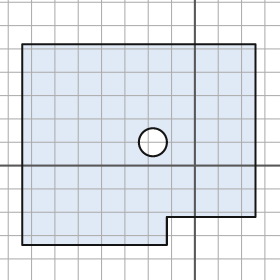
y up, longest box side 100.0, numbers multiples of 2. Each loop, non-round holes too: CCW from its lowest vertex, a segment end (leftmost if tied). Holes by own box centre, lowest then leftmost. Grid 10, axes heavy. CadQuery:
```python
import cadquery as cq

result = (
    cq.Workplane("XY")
    .moveTo(-74.0, -34.0)
    .lineTo(-12.0, -34.0)
    .lineTo(-12.0, -22.0)
    .lineTo(26.0, -22.0)
    .lineTo(26.0, 52.0)
    .lineTo(-74.0, 52.0)
    .close()
    .moveTo(-18.0, 10.0)
    .circle(6.0)
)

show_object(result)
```